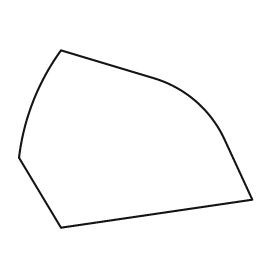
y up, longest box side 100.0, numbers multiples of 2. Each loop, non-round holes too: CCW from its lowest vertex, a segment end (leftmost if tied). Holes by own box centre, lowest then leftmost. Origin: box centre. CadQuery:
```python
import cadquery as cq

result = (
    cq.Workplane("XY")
    .moveTo(-32.0, -38.0)
    .lineTo(50.0, -26.0)
    .lineTo(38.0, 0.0)
    .threePointArc((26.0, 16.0), (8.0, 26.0))
    .lineTo(-32.0, 38.0)
    .threePointArc((-44.0, 16.0), (-50.0, -8.0))
    .close()
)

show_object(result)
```